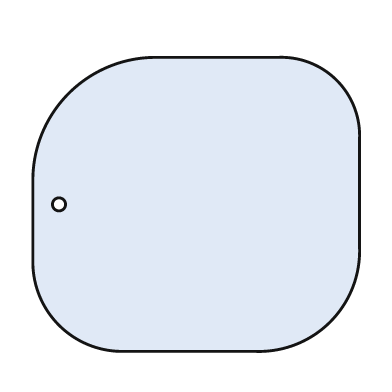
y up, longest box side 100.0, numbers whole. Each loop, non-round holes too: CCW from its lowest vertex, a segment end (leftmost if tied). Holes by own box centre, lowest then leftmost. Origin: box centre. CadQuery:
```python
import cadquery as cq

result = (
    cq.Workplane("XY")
    .moveTo(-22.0, -45.0)
    .lineTo(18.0, -45.0)
    .threePointArc((41.0, -36.0), (50.0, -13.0))
    .lineTo(50.0, 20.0)
    .threePointArc((43.0, 38.0), (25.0, 45.0))
    .lineTo(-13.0, 45.0)
    .threePointArc((-39.0, 34.0), (-50.0, 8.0))
    .lineTo(-50.0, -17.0)
    .threePointArc((-42.0, -37.0), (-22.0, -45.0))
    .close()
    .moveTo(-42.0, 0.0)
    .circle(2.0)
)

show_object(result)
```